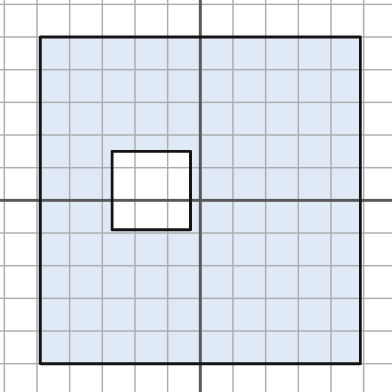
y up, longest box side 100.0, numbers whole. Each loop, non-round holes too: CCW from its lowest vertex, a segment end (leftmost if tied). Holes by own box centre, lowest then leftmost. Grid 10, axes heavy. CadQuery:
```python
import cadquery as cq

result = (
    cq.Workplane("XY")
    .moveTo(-49.0, -50.0)
    .lineTo(49.0, -50.0)
    .lineTo(49.0, 50.0)
    .lineTo(-49.0, 50.0)
    .close()
    .moveTo(-27.0, -9.0)
    .lineTo(-3.0, -9.0)
    .lineTo(-3.0, 15.0)
    .lineTo(-27.0, 15.0)
    .close()
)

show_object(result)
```